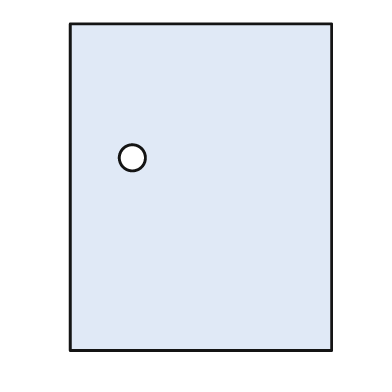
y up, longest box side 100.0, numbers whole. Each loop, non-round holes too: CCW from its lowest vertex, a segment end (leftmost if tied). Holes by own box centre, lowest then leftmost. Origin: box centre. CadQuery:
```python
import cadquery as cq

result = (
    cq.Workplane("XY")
    .moveTo(-40.0, -50.0)
    .lineTo(40.0, -50.0)
    .lineTo(40.0, 50.0)
    .lineTo(-40.0, 50.0)
    .close()
    .moveTo(-21.0, 9.0)
    .circle(4.0)
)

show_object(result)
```